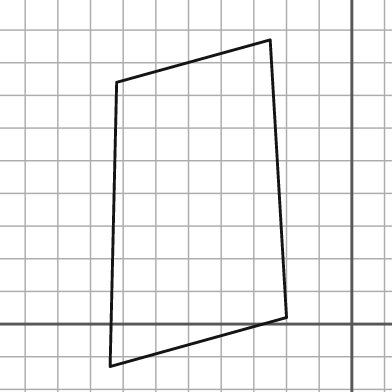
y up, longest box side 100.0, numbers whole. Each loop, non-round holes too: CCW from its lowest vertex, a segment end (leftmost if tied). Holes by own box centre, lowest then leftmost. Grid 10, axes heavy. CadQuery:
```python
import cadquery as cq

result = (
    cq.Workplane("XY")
    .moveTo(-74.0, -13.0)
    .lineTo(-20.0, 2.0)
    .lineTo(-25.0, 87.0)
    .lineTo(-72.0, 74.0)
    .close()
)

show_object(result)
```